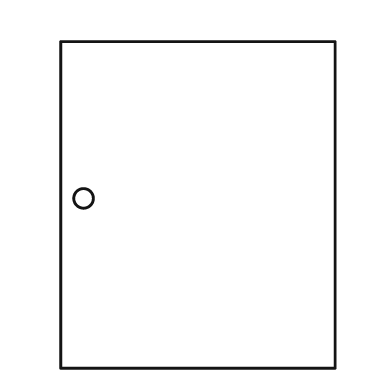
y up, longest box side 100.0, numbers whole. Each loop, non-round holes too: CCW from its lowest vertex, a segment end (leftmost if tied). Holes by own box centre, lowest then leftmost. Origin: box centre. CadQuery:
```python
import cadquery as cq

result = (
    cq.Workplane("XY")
    .moveTo(-42.0, -50.0)
    .lineTo(42.0, -50.0)
    .lineTo(42.0, 50.0)
    .lineTo(-42.0, 50.0)
    .close()
    .moveTo(-35.0, 2.0)
    .circle(3.0)
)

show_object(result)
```